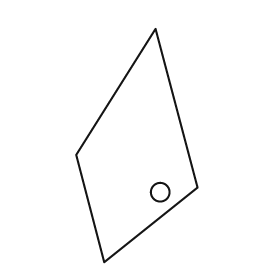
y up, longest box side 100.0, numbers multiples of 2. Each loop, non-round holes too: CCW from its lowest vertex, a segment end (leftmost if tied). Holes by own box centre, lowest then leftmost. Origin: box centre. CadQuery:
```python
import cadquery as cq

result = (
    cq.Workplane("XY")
    .moveTo(-14.0, -50.0)
    .lineTo(26.0, -18.0)
    .lineTo(8.0, 50.0)
    .lineTo(-26.0, -4.0)
    .close()
    .moveTo(10.0, -20.0)
    .circle(4.0)
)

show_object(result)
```